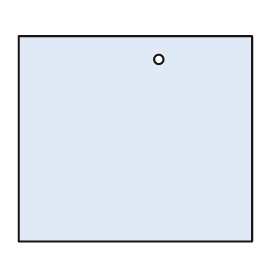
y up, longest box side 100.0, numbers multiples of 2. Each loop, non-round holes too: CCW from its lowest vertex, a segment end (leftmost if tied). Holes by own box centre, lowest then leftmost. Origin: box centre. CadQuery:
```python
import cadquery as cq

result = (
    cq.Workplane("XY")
    .moveTo(-50.0, -44.0)
    .lineTo(50.0, -44.0)
    .lineTo(50.0, 44.0)
    .lineTo(-50.0, 44.0)
    .close()
    .moveTo(10.0, 34.0)
    .circle(2.0)
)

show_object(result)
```